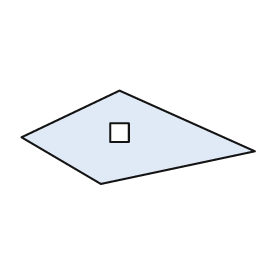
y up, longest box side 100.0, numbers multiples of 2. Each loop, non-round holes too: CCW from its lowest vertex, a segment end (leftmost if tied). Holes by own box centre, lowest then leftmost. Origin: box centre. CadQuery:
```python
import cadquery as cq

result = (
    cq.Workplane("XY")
    .moveTo(-16.0, -20.0)
    .lineTo(50.0, -6.0)
    .lineTo(-8.0, 20.0)
    .lineTo(-50.0, 0.0)
    .close()
    .moveTo(-12.0, -2.0)
    .lineTo(-4.0, -2.0)
    .lineTo(-4.0, 6.0)
    .lineTo(-12.0, 6.0)
    .close()
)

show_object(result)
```